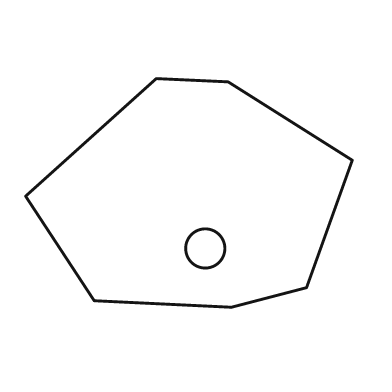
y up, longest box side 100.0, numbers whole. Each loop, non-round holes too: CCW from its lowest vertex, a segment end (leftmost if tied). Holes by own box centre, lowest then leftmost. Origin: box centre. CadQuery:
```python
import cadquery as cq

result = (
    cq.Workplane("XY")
    .moveTo(13.0, -35.0)
    .lineTo(36.0, -29.0)
    .lineTo(50.0, 10.0)
    .lineTo(12.0, 34.0)
    .lineTo(-10.0, 35.0)
    .lineTo(-50.0, -1.0)
    .lineTo(-29.0, -33.0)
    .close()
    .moveTo(5.0, -17.0)
    .circle(6.0)
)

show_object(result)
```